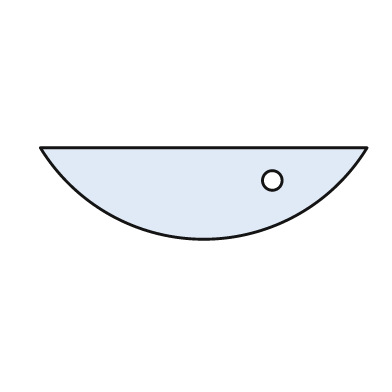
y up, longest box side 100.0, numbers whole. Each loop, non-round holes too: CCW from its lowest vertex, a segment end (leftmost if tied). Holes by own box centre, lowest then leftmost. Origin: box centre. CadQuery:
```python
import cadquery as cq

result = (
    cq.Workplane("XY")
    .moveTo(-50.0, 14.0)
    .threePointArc((0.0, -14.0), (50.0, 14.0))
    .close()
    .moveTo(21.0, 4.0)
    .circle(3.0)
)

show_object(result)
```